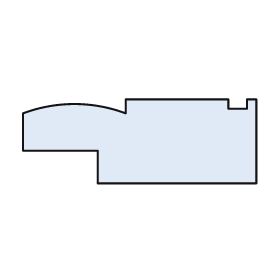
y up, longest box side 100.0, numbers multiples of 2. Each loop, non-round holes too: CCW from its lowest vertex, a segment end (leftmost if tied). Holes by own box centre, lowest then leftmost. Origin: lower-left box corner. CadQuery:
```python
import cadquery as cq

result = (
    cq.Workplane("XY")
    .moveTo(32.0, 0.0)
    .lineTo(100.0, 0.0)
    .lineTo(100.0, 36.0)
    .lineTo(96.0, 36.0)
    .lineTo(96.0, 32.0)
    .lineTo(88.0, 32.0)
    .lineTo(88.0, 36.0)
    .lineTo(44.0, 36.0)
    .lineTo(44.0, 30.0)
    .threePointArc((22.0, 34.0), (0.0, 30.0))
    .lineTo(0.0, 14.0)
    .lineTo(32.0, 14.0)
    .close()
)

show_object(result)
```